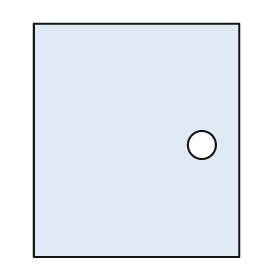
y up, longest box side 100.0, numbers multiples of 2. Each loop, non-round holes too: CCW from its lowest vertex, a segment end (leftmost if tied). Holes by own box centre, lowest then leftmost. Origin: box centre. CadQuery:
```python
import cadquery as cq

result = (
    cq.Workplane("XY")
    .moveTo(-44.0, -50.0)
    .lineTo(44.0, -50.0)
    .lineTo(44.0, 50.0)
    .lineTo(-44.0, 50.0)
    .close()
    .moveTo(28.0, -2.0)
    .circle(6.0)
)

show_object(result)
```